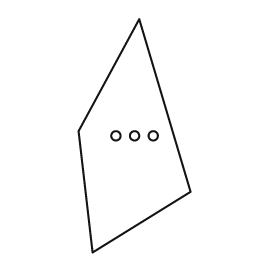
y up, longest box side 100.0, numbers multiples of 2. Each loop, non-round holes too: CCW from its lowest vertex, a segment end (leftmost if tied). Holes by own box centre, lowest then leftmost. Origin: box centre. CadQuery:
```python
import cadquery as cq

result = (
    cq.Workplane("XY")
    .moveTo(-18.0, -50.0)
    .lineTo(24.0, -24.0)
    .lineTo(2.0, 50.0)
    .lineTo(-24.0, 2.0)
    .close()
    .moveTo(-8.0, 0.0)
    .circle(2.0)
    .moveTo(0.0, 0.0)
    .circle(2.0)
    .moveTo(8.0, 0.0)
    .circle(2.0)
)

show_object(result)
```